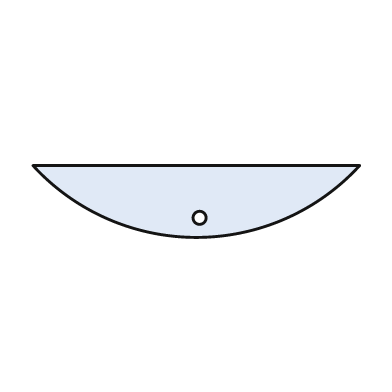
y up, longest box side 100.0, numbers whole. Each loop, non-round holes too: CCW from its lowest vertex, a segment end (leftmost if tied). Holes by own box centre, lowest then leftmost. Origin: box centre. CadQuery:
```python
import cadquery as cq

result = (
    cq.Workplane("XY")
    .moveTo(-50.0, 11.0)
    .threePointArc((0.0, -11.0), (50.0, 11.0))
    .close()
    .moveTo(1.0, -5.0)
    .circle(2.0)
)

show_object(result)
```